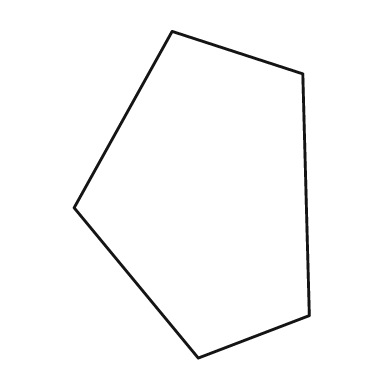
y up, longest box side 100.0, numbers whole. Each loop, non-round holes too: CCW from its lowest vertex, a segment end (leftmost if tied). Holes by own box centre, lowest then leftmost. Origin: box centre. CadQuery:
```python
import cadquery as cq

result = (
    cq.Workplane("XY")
    .moveTo(2.0, -50.0)
    .lineTo(36.0, -37.0)
    .lineTo(34.0, 37.0)
    .lineTo(-6.0, 50.0)
    .lineTo(-36.0, -4.0)
    .close()
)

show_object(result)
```